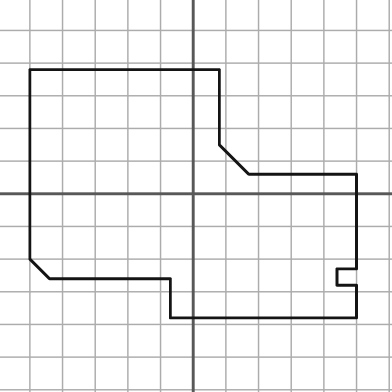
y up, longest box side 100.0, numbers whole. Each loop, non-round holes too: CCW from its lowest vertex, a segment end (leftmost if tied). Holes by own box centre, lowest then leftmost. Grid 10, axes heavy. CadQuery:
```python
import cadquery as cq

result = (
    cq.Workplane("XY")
    .moveTo(-7.0, -38.0)
    .lineTo(50.0, -38.0)
    .lineTo(50.0, -28.0)
    .lineTo(44.0, -28.0)
    .lineTo(44.0, -23.0)
    .lineTo(50.0, -23.0)
    .lineTo(50.0, 6.0)
    .lineTo(17.0, 6.0)
    .lineTo(8.0, 15.0)
    .lineTo(8.0, 38.0)
    .lineTo(-50.0, 38.0)
    .lineTo(-50.0, -20.0)
    .lineTo(-44.0, -26.0)
    .lineTo(-7.0, -26.0)
    .close()
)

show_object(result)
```